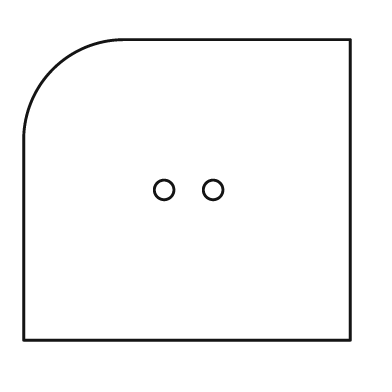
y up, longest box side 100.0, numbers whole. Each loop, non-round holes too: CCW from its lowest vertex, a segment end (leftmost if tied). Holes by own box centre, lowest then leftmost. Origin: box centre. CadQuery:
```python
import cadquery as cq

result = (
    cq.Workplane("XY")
    .moveTo(-50.0, -46.0)
    .lineTo(50.0, -46.0)
    .lineTo(50.0, 46.0)
    .lineTo(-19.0, 46.0)
    .threePointArc((-41.0, 37.0), (-50.0, 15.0))
    .close()
    .moveTo(-7.0, 0.0)
    .circle(3.0)
    .moveTo(8.0, 0.0)
    .circle(3.0)
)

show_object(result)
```